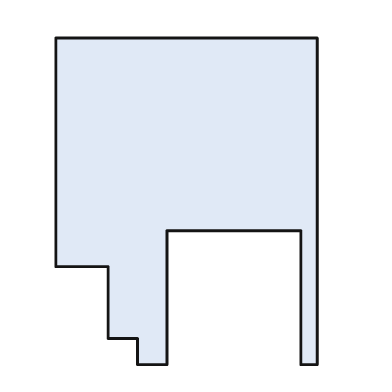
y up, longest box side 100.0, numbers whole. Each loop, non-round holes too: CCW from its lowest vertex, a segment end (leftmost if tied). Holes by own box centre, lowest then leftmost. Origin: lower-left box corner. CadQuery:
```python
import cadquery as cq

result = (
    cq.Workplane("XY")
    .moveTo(25.0, 0.0)
    .lineTo(34.0, 0.0)
    .lineTo(34.0, 41.0)
    .lineTo(75.0, 41.0)
    .lineTo(75.0, 0.0)
    .lineTo(80.0, 0.0)
    .lineTo(80.0, 100.0)
    .lineTo(0.0, 100.0)
    .lineTo(0.0, 30.0)
    .lineTo(16.0, 30.0)
    .lineTo(16.0, 8.0)
    .lineTo(25.0, 8.0)
    .close()
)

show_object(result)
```